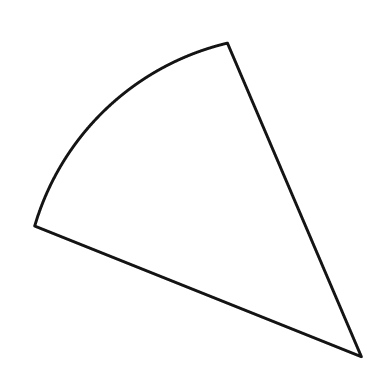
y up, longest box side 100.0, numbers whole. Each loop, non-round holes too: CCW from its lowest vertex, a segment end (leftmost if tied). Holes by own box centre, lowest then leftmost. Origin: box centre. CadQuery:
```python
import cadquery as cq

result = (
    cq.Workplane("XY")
    .moveTo(50.0, -48.0)
    .lineTo(9.0, 48.0)
    .threePointArc((-28.0, 28.0), (-50.0, -8.0))
    .close()
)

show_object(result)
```